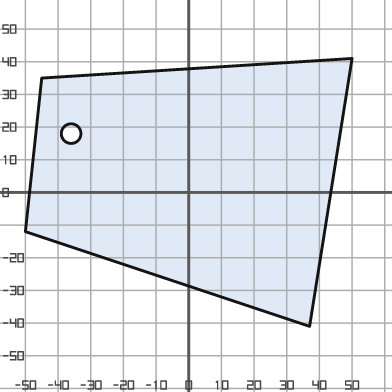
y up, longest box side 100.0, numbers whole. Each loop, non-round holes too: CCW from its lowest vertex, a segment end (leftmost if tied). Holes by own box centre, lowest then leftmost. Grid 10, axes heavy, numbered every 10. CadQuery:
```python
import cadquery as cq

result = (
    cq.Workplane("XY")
    .moveTo(37.0, -41.0)
    .lineTo(50.0, 41.0)
    .lineTo(-45.0, 35.0)
    .lineTo(-50.0, -12.0)
    .close()
    .moveTo(-36.0, 18.0)
    .circle(3.0)
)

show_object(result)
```